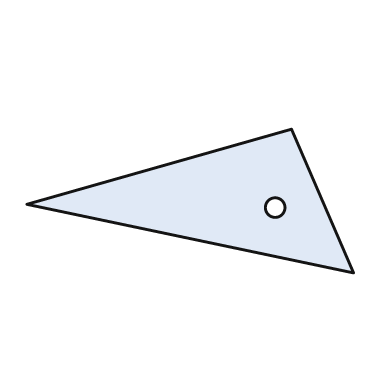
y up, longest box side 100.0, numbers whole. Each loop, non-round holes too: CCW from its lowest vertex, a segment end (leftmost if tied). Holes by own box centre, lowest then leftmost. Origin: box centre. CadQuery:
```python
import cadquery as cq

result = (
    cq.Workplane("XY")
    .moveTo(50.0, -22.0)
    .lineTo(31.0, 22.0)
    .lineTo(-50.0, -1.0)
    .close()
    .moveTo(26.0, -2.0)
    .circle(3.0)
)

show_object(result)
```